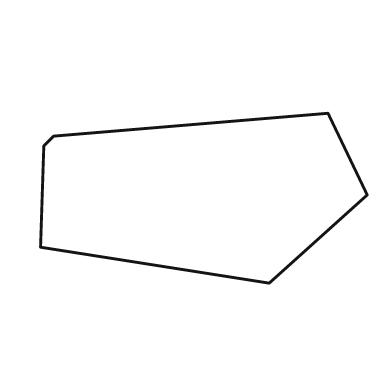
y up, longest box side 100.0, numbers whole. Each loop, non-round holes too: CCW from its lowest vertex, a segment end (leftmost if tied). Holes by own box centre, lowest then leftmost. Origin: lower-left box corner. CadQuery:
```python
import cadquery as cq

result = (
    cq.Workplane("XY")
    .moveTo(70.0, 0.0)
    .lineTo(100.0, 27.0)
    .lineTo(88.0, 52.0)
    .lineTo(4.0, 45.0)
    .lineTo(1.0, 42.0)
    .lineTo(0.0, 11.0)
    .close()
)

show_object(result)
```